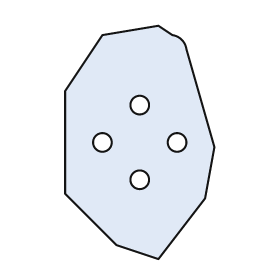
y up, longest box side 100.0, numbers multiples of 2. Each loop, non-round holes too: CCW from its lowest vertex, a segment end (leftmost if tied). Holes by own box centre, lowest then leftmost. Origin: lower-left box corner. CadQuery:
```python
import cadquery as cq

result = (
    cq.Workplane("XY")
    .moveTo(40.0, 0.0)
    .lineTo(60.0, 26.0)
    .lineTo(64.0, 48.0)
    .lineTo(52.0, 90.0)
    .threePointArc((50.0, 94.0), (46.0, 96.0))
    .lineTo(40.0, 100.0)
    .lineTo(16.0, 96.0)
    .lineTo(0.0, 72.0)
    .lineTo(0.0, 28.0)
    .lineTo(22.0, 6.0)
    .close()
    .moveTo(32.0, 34.0)
    .circle(4.0)
    .moveTo(16.0, 50.0)
    .circle(4.0)
    .moveTo(48.0, 50.0)
    .circle(4.0)
    .moveTo(32.0, 66.0)
    .circle(4.0)
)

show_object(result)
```